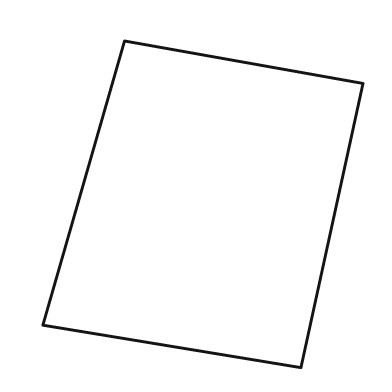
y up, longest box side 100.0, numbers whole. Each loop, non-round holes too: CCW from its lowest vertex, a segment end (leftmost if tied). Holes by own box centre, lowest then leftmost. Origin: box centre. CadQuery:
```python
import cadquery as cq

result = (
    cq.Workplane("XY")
    .moveTo(30.0, -50.0)
    .lineTo(49.0, 37.0)
    .lineTo(-24.0, 50.0)
    .lineTo(-49.0, -37.0)
    .close()
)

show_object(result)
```